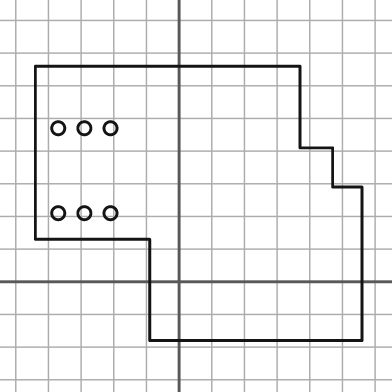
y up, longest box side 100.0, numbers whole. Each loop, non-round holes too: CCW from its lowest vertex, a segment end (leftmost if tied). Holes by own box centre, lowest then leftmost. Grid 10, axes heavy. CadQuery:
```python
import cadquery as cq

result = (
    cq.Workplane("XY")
    .moveTo(-9.0, -18.0)
    .lineTo(56.0, -18.0)
    .lineTo(56.0, 29.0)
    .lineTo(47.0, 29.0)
    .lineTo(47.0, 41.0)
    .lineTo(37.0, 41.0)
    .lineTo(37.0, 66.0)
    .lineTo(-44.0, 66.0)
    .lineTo(-44.0, 13.0)
    .lineTo(-9.0, 13.0)
    .close()
    .moveTo(-37.0, 21.0)
    .circle(2.0)
    .moveTo(-29.0, 21.0)
    .circle(2.0)
    .moveTo(-21.0, 21.0)
    .circle(2.0)
    .moveTo(-37.0, 47.0)
    .circle(2.0)
    .moveTo(-29.0, 47.0)
    .circle(2.0)
    .moveTo(-21.0, 47.0)
    .circle(2.0)
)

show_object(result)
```